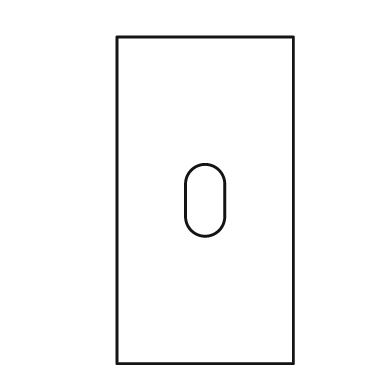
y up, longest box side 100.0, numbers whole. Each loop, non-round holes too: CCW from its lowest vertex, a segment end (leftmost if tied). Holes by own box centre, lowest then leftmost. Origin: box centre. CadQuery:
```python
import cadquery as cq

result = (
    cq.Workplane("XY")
    .moveTo(-27.0, -50.0)
    .lineTo(27.0, -50.0)
    .lineTo(27.0, 50.0)
    .lineTo(-27.0, 50.0)
    .close()
    .moveTo(-6.0, -5.0)
    .threePointArc((0.0, -11.0), (6.0, -5.0))
    .lineTo(6.0, 5.0)
    .threePointArc((0.0, 11.0), (-6.0, 5.0))
    .close()
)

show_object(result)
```